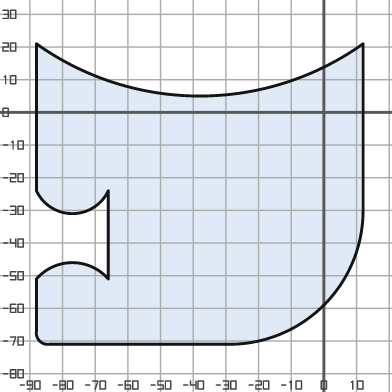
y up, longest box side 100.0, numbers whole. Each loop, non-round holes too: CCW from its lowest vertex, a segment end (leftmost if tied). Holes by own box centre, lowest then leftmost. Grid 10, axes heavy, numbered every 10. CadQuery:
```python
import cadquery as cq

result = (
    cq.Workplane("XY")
    .moveTo(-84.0, -71.0)
    .lineTo(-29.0, -71.0)
    .threePointArc((0.0, -59.0), (12.0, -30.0))
    .lineTo(12.0, 21.0)
    .threePointArc((-38.0, 5.0), (-88.0, 21.0))
    .lineTo(-88.0, -24.0)
    .threePointArc((-77.0, -31.0), (-66.0, -24.0))
    .lineTo(-66.0, -51.0)
    .threePointArc((-77.0, -46.0), (-88.0, -51.0))
    .lineTo(-88.0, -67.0)
    .threePointArc((-87.0, -70.0), (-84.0, -71.0))
    .close()
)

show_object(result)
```